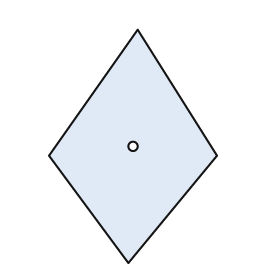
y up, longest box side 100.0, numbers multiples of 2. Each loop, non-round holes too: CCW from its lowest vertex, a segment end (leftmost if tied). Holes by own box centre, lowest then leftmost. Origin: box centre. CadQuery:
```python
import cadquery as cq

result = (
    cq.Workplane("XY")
    .moveTo(-2.0, -50.0)
    .lineTo(36.0, -4.0)
    .lineTo(2.0, 50.0)
    .lineTo(-36.0, -4.0)
    .close()
    .moveTo(0.0, 0.0)
    .circle(2.0)
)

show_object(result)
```